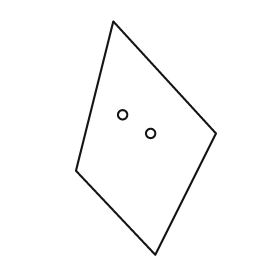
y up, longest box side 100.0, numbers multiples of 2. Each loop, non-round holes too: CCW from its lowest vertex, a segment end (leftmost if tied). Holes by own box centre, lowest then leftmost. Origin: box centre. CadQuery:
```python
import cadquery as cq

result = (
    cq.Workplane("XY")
    .moveTo(4.0, -50.0)
    .lineTo(30.0, 2.0)
    .lineTo(-14.0, 50.0)
    .lineTo(-30.0, -14.0)
    .close()
    .moveTo(2.0, 2.0)
    .circle(2.0)
    .moveTo(-10.0, 10.0)
    .circle(2.0)
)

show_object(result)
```